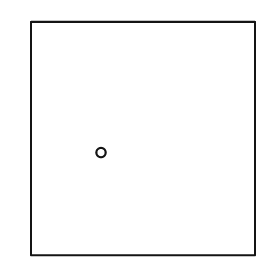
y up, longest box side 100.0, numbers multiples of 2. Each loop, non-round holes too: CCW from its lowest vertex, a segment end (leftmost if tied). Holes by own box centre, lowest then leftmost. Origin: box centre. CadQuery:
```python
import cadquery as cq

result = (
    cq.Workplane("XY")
    .moveTo(-48.0, -50.0)
    .lineTo(48.0, -50.0)
    .lineTo(48.0, 50.0)
    .lineTo(-48.0, 50.0)
    .close()
    .moveTo(-18.0, -6.0)
    .circle(2.0)
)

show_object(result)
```